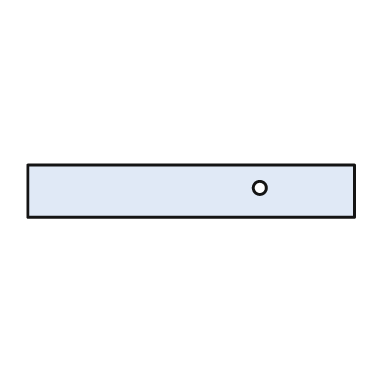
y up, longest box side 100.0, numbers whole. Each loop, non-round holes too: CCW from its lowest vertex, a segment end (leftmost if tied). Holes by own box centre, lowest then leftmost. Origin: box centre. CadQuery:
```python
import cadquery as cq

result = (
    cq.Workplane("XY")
    .moveTo(-50.0, -8.0)
    .lineTo(50.0, -8.0)
    .lineTo(50.0, 8.0)
    .lineTo(-50.0, 8.0)
    .close()
    .moveTo(21.0, 1.0)
    .circle(2.0)
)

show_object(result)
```